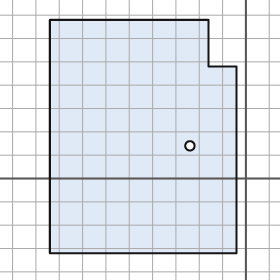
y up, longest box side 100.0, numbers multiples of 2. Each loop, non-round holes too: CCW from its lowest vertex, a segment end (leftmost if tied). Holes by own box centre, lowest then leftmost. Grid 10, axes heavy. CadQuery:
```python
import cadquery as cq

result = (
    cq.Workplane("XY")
    .moveTo(-84.0, -32.0)
    .lineTo(-4.0, -32.0)
    .lineTo(-4.0, 48.0)
    .lineTo(-16.0, 48.0)
    .lineTo(-16.0, 68.0)
    .lineTo(-84.0, 68.0)
    .close()
    .moveTo(-24.0, 14.0)
    .circle(2.0)
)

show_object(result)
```